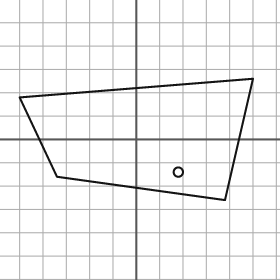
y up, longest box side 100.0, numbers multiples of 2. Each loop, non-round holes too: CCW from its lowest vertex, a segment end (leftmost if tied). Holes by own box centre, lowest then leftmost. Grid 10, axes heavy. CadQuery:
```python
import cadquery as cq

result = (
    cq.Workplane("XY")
    .moveTo(38.0, -26.0)
    .lineTo(50.0, 26.0)
    .lineTo(-50.0, 18.0)
    .lineTo(-34.0, -16.0)
    .close()
    .moveTo(18.0, -14.0)
    .circle(2.0)
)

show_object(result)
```